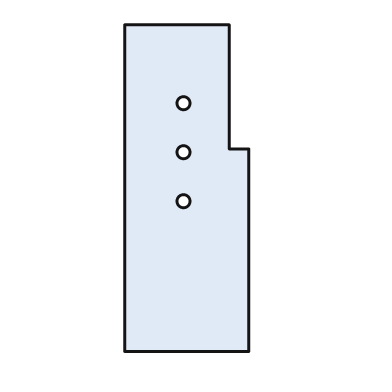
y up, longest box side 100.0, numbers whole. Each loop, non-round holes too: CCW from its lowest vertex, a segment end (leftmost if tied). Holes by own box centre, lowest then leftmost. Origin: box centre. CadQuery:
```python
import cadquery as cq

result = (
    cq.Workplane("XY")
    .moveTo(-19.0, -50.0)
    .lineTo(19.0, -50.0)
    .lineTo(19.0, 12.0)
    .lineTo(13.0, 12.0)
    .lineTo(13.0, 50.0)
    .lineTo(-19.0, 50.0)
    .close()
    .moveTo(-1.0, -4.0)
    .circle(2.0)
    .moveTo(-1.0, 11.0)
    .circle(2.0)
    .moveTo(-1.0, 26.0)
    .circle(2.0)
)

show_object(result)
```